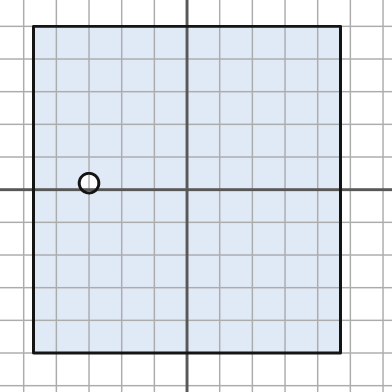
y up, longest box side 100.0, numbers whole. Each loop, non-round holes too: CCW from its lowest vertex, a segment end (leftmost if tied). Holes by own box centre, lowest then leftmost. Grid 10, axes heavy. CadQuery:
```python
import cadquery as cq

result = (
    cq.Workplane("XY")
    .moveTo(-47.0, -50.0)
    .lineTo(47.0, -50.0)
    .lineTo(47.0, 50.0)
    .lineTo(-47.0, 50.0)
    .close()
    .moveTo(-30.0, 2.0)
    .circle(3.0)
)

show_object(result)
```